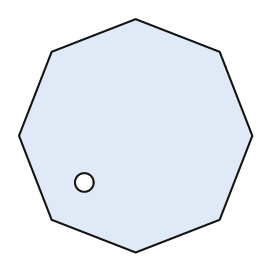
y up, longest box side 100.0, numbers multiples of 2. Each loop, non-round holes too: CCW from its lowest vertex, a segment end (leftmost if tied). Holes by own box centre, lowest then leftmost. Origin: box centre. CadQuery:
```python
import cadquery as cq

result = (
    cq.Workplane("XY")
    .moveTo(0.0, -50.0)
    .lineTo(36.0, -36.0)
    .lineTo(50.0, 0.0)
    .lineTo(36.0, 36.0)
    .lineTo(0.0, 50.0)
    .lineTo(-36.0, 36.0)
    .lineTo(-50.0, 0.0)
    .lineTo(-36.0, -36.0)
    .close()
    .moveTo(-22.0, -20.0)
    .circle(4.0)
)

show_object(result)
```